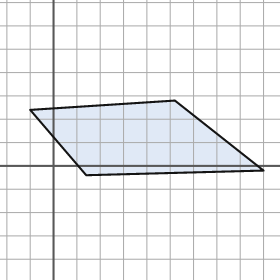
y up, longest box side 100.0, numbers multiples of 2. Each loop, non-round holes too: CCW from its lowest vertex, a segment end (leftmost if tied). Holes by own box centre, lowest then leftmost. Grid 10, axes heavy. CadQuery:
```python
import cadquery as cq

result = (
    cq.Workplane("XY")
    .moveTo(14.0, -4.0)
    .lineTo(90.0, -2.0)
    .lineTo(52.0, 28.0)
    .lineTo(-10.0, 24.0)
    .close()
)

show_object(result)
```